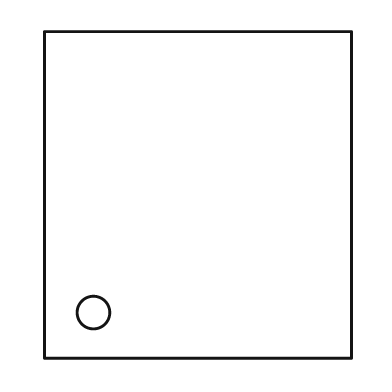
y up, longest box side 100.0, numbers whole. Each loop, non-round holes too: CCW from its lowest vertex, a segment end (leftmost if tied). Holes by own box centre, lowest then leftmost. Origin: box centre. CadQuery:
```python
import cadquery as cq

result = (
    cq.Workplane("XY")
    .moveTo(-47.0, -50.0)
    .lineTo(47.0, -50.0)
    .lineTo(47.0, 50.0)
    .lineTo(-47.0, 50.0)
    .close()
    .moveTo(-32.0, -36.0)
    .circle(5.0)
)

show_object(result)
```